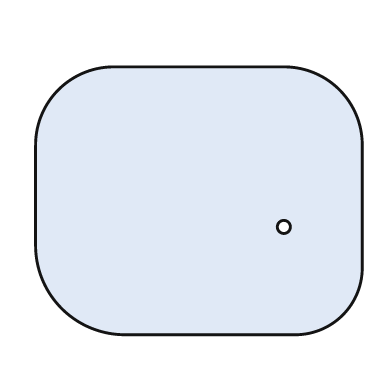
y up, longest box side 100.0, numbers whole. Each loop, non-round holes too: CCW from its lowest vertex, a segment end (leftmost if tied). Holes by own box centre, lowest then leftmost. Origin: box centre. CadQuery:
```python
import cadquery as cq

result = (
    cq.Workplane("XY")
    .moveTo(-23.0, -41.0)
    .lineTo(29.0, -41.0)
    .threePointArc((44.0, -35.0), (50.0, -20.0))
    .lineTo(50.0, 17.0)
    .threePointArc((43.0, 34.0), (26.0, 41.0))
    .lineTo(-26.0, 41.0)
    .threePointArc((-43.0, 34.0), (-50.0, 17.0))
    .lineTo(-50.0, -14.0)
    .threePointArc((-42.0, -33.0), (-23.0, -41.0))
    .close()
    .moveTo(26.0, -8.0)
    .circle(2.0)
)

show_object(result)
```